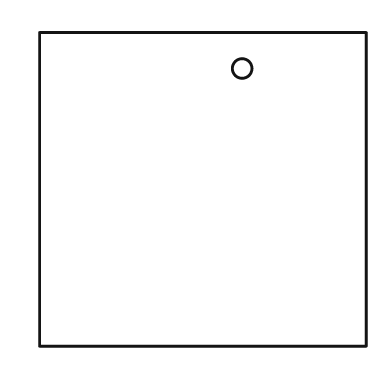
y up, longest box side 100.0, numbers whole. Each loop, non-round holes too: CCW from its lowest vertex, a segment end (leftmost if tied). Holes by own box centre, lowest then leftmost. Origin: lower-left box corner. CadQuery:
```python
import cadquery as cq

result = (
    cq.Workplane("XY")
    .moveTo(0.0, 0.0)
    .lineTo(100.0, 0.0)
    .lineTo(100.0, 96.0)
    .lineTo(0.0, 96.0)
    .close()
    .moveTo(62.0, 85.0)
    .circle(3.0)
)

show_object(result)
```